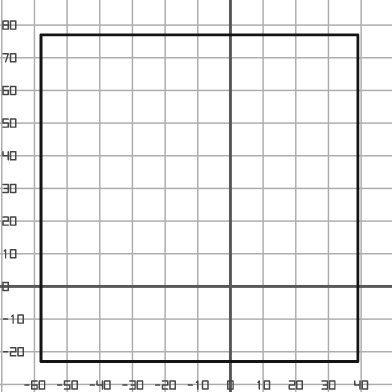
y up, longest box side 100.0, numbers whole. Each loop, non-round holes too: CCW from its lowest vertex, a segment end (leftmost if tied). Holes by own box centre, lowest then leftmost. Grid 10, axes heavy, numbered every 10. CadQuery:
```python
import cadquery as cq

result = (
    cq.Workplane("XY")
    .moveTo(-58.0, -23.0)
    .lineTo(39.0, -23.0)
    .lineTo(39.0, 77.0)
    .lineTo(-58.0, 77.0)
    .close()
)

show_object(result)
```